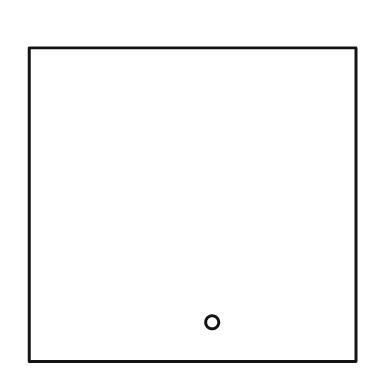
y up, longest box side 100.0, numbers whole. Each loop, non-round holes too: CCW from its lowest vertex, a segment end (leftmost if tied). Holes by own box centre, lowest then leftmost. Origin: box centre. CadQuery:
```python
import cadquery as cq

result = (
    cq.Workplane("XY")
    .moveTo(-50.0, -48.0)
    .lineTo(50.0, -48.0)
    .lineTo(50.0, 48.0)
    .lineTo(-50.0, 48.0)
    .close()
    .moveTo(6.0, -36.0)
    .circle(2.0)
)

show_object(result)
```